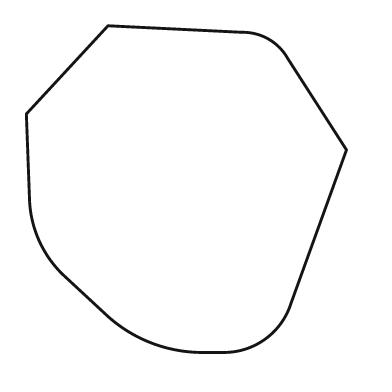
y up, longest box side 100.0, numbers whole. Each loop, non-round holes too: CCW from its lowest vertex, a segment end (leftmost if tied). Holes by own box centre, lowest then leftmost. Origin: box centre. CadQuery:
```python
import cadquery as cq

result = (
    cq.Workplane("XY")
    .moveTo(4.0, -50.0)
    .lineTo(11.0, -50.0)
    .threePointArc((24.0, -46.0), (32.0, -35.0))
    .lineTo(49.0, 12.0)
    .lineTo(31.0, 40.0)
    .threePointArc((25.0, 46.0), (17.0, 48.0))
    .lineTo(-24.0, 50.0)
    .lineTo(-49.0, 23.0)
    .lineTo(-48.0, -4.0)
    .threePointArc((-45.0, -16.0), (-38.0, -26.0))
    .lineTo(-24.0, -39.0)
    .threePointArc((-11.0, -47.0), (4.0, -50.0))
    .close()
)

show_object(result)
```